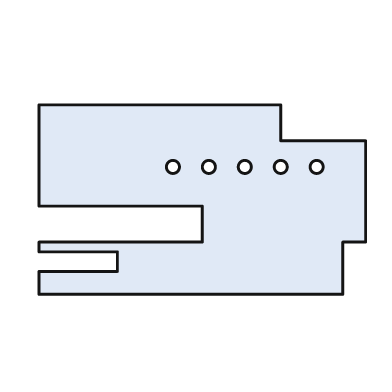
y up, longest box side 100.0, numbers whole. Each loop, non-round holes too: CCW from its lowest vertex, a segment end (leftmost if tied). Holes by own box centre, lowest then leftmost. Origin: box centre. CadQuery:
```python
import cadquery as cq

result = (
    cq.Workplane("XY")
    .moveTo(-50.0, -29.0)
    .lineTo(43.0, -29.0)
    .lineTo(43.0, -13.0)
    .lineTo(50.0, -13.0)
    .lineTo(50.0, 18.0)
    .lineTo(24.0, 18.0)
    .lineTo(24.0, 29.0)
    .lineTo(-50.0, 29.0)
    .lineTo(-50.0, -2.0)
    .lineTo(0.0, -2.0)
    .lineTo(0.0, -13.0)
    .lineTo(-50.0, -13.0)
    .lineTo(-50.0, -16.0)
    .lineTo(-26.0, -16.0)
    .lineTo(-26.0, -22.0)
    .lineTo(-50.0, -22.0)
    .close()
    .moveTo(-9.0, 10.0)
    .circle(2.0)
    .moveTo(2.0, 10.0)
    .circle(2.0)
    .moveTo(13.0, 10.0)
    .circle(2.0)
    .moveTo(24.0, 10.0)
    .circle(2.0)
    .moveTo(35.0, 10.0)
    .circle(2.0)
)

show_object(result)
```